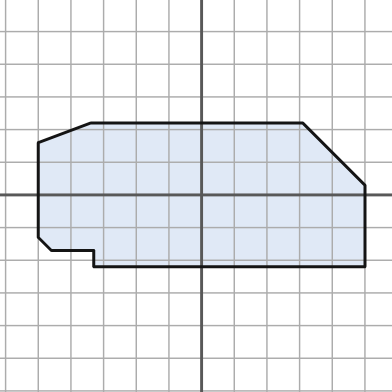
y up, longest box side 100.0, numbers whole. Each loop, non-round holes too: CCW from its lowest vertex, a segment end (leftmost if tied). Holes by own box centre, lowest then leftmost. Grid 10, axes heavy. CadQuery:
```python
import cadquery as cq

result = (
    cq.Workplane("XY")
    .moveTo(-33.0, -22.0)
    .lineTo(50.0, -22.0)
    .lineTo(50.0, 3.0)
    .lineTo(31.0, 22.0)
    .lineTo(-34.0, 22.0)
    .lineTo(-50.0, 16.0)
    .lineTo(-50.0, -13.0)
    .lineTo(-46.0, -17.0)
    .lineTo(-33.0, -17.0)
    .close()
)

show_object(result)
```